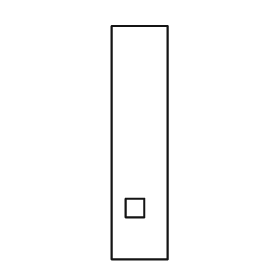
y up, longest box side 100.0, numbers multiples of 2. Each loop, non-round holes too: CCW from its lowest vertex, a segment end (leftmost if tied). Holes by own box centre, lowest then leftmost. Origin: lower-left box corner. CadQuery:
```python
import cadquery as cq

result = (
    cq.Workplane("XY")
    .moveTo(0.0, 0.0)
    .lineTo(24.0, 0.0)
    .lineTo(24.0, 100.0)
    .lineTo(0.0, 100.0)
    .close()
    .moveTo(6.0, 18.0)
    .lineTo(14.0, 18.0)
    .lineTo(14.0, 26.0)
    .lineTo(6.0, 26.0)
    .close()
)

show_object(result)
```